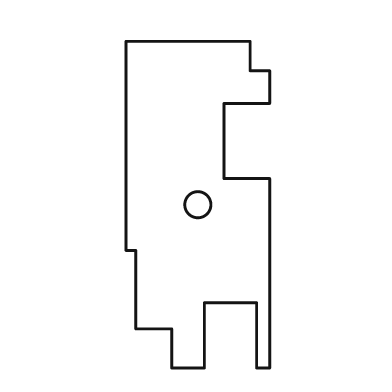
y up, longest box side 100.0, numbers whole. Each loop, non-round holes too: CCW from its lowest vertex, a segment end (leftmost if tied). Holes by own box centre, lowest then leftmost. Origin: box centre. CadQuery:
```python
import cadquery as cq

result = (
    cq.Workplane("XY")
    .moveTo(-8.0, -50.0)
    .lineTo(2.0, -50.0)
    .lineTo(2.0, -30.0)
    .lineTo(18.0, -30.0)
    .lineTo(18.0, -50.0)
    .lineTo(22.0, -50.0)
    .lineTo(22.0, 8.0)
    .lineTo(8.0, 8.0)
    .lineTo(8.0, 31.0)
    .lineTo(22.0, 31.0)
    .lineTo(22.0, 41.0)
    .lineTo(16.0, 41.0)
    .lineTo(16.0, 50.0)
    .lineTo(-22.0, 50.0)
    .lineTo(-22.0, -14.0)
    .lineTo(-19.0, -14.0)
    .lineTo(-19.0, -38.0)
    .lineTo(-8.0, -38.0)
    .close()
    .moveTo(0.0, 0.0)
    .circle(4.0)
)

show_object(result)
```